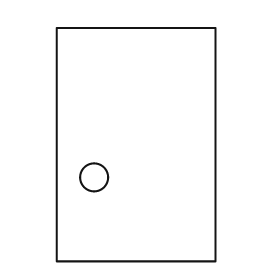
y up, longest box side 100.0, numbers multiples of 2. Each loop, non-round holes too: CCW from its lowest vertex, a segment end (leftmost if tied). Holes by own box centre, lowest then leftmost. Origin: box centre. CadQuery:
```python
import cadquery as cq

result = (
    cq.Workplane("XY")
    .moveTo(-34.0, -50.0)
    .lineTo(34.0, -50.0)
    .lineTo(34.0, 50.0)
    .lineTo(-34.0, 50.0)
    .close()
    .moveTo(-18.0, -14.0)
    .circle(6.0)
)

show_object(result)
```